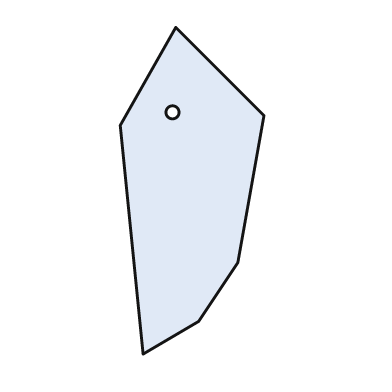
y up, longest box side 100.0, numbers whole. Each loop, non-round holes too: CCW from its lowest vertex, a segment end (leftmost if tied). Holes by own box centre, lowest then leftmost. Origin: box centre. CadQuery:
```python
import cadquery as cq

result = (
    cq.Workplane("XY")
    .moveTo(-15.0, -50.0)
    .lineTo(2.0, -40.0)
    .lineTo(14.0, -22.0)
    .lineTo(22.0, 23.0)
    .lineTo(-5.0, 50.0)
    .lineTo(-22.0, 20.0)
    .close()
    .moveTo(-6.0, 24.0)
    .circle(2.0)
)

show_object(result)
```